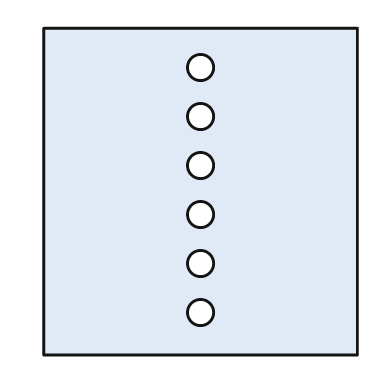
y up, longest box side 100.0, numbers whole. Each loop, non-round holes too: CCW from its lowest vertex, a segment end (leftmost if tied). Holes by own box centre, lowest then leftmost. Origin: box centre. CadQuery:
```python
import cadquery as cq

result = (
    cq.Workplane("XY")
    .moveTo(-48.0, -50.0)
    .lineTo(48.0, -50.0)
    .lineTo(48.0, 50.0)
    .lineTo(-48.0, 50.0)
    .close()
    .moveTo(0.0, -37.0)
    .circle(4.0)
    .moveTo(0.0, -22.0)
    .circle(4.0)
    .moveTo(0.0, -7.0)
    .circle(4.0)
    .moveTo(0.0, 8.0)
    .circle(4.0)
    .moveTo(0.0, 23.0)
    .circle(4.0)
    .moveTo(0.0, 38.0)
    .circle(4.0)
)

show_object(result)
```